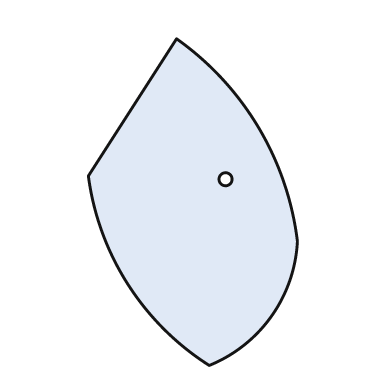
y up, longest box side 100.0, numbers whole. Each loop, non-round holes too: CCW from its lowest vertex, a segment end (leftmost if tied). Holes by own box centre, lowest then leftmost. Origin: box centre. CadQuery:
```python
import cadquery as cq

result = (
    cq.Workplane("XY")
    .moveTo(5.0, -50.0)
    .threePointArc((24.0, -35.0), (32.0, -12.0))
    .threePointArc((20.0, 23.0), (-5.0, 50.0))
    .lineTo(-32.0, 8.0)
    .threePointArc((-20.0, -25.0), (5.0, -50.0))
    .close()
    .moveTo(10.0, 7.0)
    .circle(2.0)
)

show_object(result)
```